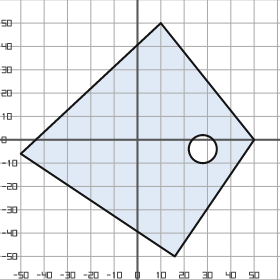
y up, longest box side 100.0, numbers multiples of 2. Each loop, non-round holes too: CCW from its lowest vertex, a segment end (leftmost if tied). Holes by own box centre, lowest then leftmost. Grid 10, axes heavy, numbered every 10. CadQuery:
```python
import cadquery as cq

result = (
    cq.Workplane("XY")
    .moveTo(16.0, -50.0)
    .lineTo(50.0, 0.0)
    .lineTo(10.0, 50.0)
    .lineTo(-50.0, -6.0)
    .close()
    .moveTo(28.0, -4.0)
    .circle(6.0)
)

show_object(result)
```